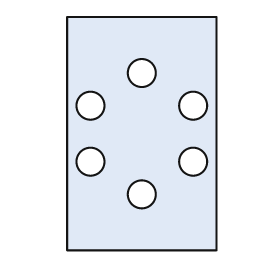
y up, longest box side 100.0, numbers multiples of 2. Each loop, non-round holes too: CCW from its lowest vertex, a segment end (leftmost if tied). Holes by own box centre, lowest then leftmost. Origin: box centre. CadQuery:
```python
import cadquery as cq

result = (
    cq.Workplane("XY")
    .moveTo(-32.0, -50.0)
    .lineTo(32.0, -50.0)
    .lineTo(32.0, 50.0)
    .lineTo(-32.0, 50.0)
    .close()
    .moveTo(0.0, -26.0)
    .circle(6.0)
    .moveTo(-22.0, -12.0)
    .circle(6.0)
    .moveTo(22.0, -12.0)
    .circle(6.0)
    .moveTo(-22.0, 12.0)
    .circle(6.0)
    .moveTo(22.0, 12.0)
    .circle(6.0)
    .moveTo(0.0, 26.0)
    .circle(6.0)
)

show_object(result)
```